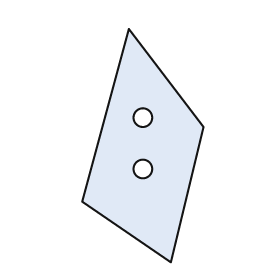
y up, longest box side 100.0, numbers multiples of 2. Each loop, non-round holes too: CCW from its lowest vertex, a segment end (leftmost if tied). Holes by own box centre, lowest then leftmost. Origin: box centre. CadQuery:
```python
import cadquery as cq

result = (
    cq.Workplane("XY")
    .moveTo(12.0, -50.0)
    .lineTo(26.0, 8.0)
    .lineTo(-6.0, 50.0)
    .lineTo(-26.0, -24.0)
    .close()
    .moveTo(0.0, -10.0)
    .circle(4.0)
    .moveTo(0.0, 12.0)
    .circle(4.0)
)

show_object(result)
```